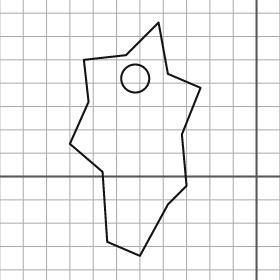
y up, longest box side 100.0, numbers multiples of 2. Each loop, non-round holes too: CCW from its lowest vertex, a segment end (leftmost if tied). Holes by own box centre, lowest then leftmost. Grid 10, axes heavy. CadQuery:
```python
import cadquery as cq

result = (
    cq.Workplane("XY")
    .moveTo(-50.0, -34.0)
    .lineTo(-38.0, -12.0)
    .lineTo(-30.0, -4.0)
    .lineTo(-32.0, 18.0)
    .lineTo(-24.0, 38.0)
    .lineTo(-38.0, 44.0)
    .lineTo(-42.0, 66.0)
    .lineTo(-56.0, 52.0)
    .lineTo(-74.0, 50.0)
    .lineTo(-72.0, 32.0)
    .lineTo(-80.0, 14.0)
    .lineTo(-66.0, 2.0)
    .lineTo(-64.0, -28.0)
    .close()
    .moveTo(-52.0, 42.0)
    .circle(6.0)
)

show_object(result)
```